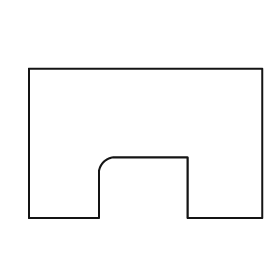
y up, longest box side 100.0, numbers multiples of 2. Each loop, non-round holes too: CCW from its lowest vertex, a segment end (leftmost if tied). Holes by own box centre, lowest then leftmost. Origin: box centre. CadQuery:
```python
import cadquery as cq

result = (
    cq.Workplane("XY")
    .moveTo(-50.0, -32.0)
    .lineTo(-20.0, -32.0)
    .lineTo(-20.0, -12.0)
    .threePointArc((-18.0, -8.0), (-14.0, -6.0))
    .lineTo(18.0, -6.0)
    .lineTo(18.0, -32.0)
    .lineTo(50.0, -32.0)
    .lineTo(50.0, 32.0)
    .lineTo(-50.0, 32.0)
    .close()
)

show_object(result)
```